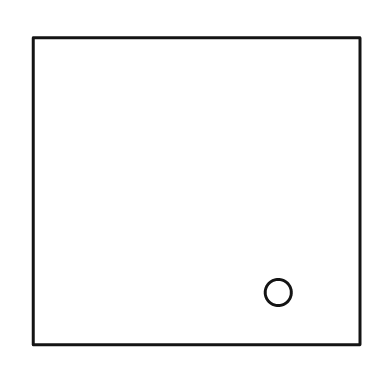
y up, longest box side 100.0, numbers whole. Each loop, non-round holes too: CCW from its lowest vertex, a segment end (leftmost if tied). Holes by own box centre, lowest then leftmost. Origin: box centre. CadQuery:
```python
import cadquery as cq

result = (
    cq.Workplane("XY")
    .moveTo(-50.0, -47.0)
    .lineTo(50.0, -47.0)
    .lineTo(50.0, 47.0)
    .lineTo(-50.0, 47.0)
    .close()
    .moveTo(25.0, -31.0)
    .circle(4.0)
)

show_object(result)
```